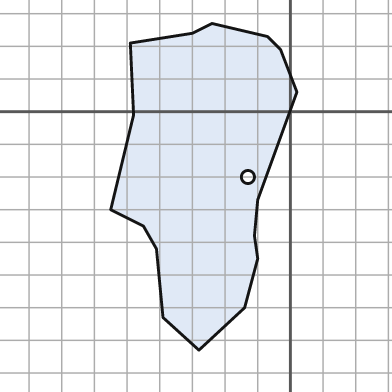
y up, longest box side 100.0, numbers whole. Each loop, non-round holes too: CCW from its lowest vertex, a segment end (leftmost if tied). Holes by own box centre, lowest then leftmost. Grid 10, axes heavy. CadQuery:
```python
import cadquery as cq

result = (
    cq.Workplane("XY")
    .moveTo(-28.0, -73.0)
    .lineTo(-14.0, -60.0)
    .lineTo(-10.0, -45.0)
    .lineTo(-11.0, -38.0)
    .lineTo(-10.0, -27.0)
    .lineTo(2.0, 6.0)
    .lineTo(-3.0, 19.0)
    .lineTo(-7.0, 23.0)
    .lineTo(-24.0, 27.0)
    .lineTo(-30.0, 24.0)
    .lineTo(-49.0, 21.0)
    .lineTo(-48.0, -1.0)
    .lineTo(-55.0, -30.0)
    .lineTo(-45.0, -35.0)
    .lineTo(-41.0, -42.0)
    .lineTo(-39.0, -63.0)
    .close()
    .moveTo(-13.0, -20.0)
    .circle(2.0)
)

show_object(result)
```